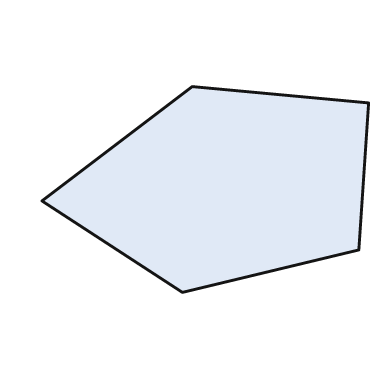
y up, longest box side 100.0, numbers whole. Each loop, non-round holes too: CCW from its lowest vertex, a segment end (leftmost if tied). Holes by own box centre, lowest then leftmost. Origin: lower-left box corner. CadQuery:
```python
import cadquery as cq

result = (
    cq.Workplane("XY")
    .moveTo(43.0, 0.0)
    .lineTo(97.0, 13.0)
    .lineTo(100.0, 58.0)
    .lineTo(46.0, 63.0)
    .lineTo(0.0, 28.0)
    .close()
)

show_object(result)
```